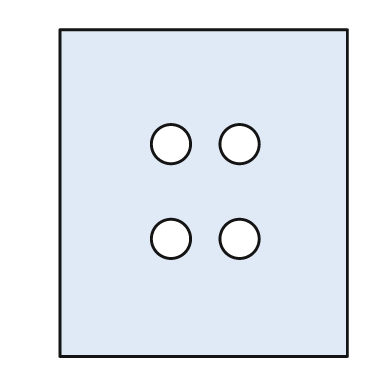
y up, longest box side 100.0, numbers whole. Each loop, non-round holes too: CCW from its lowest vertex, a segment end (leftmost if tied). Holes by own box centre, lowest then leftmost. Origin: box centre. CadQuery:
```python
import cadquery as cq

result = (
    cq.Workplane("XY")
    .moveTo(-44.0, -50.0)
    .lineTo(44.0, -50.0)
    .lineTo(44.0, 50.0)
    .lineTo(-44.0, 50.0)
    .close()
    .moveTo(-10.0, -14.0)
    .circle(6.0)
    .moveTo(11.0, -14.0)
    .circle(6.0)
    .moveTo(-10.0, 15.0)
    .circle(6.0)
    .moveTo(11.0, 15.0)
    .circle(6.0)
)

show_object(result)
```